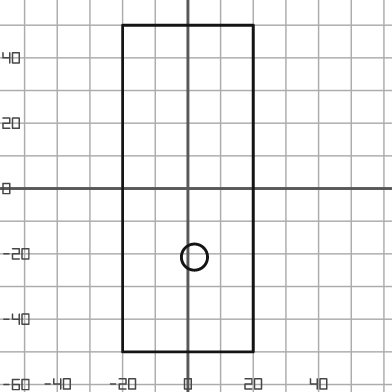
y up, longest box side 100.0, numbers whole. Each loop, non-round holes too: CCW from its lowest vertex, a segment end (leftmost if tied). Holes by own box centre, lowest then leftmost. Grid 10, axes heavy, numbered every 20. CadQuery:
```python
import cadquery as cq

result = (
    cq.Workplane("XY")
    .moveTo(-20.0, -50.0)
    .lineTo(20.0, -50.0)
    .lineTo(20.0, 50.0)
    .lineTo(-20.0, 50.0)
    .close()
    .moveTo(2.0, -21.0)
    .circle(4.0)
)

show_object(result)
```